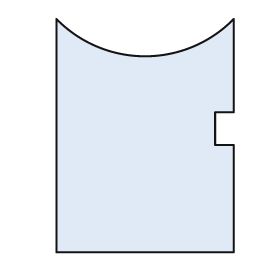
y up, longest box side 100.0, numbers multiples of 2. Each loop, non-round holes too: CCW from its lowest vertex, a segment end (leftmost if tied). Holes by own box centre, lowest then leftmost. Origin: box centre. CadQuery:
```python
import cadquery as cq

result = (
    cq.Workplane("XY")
    .moveTo(-38.0, -50.0)
    .lineTo(38.0, -50.0)
    .lineTo(38.0, -4.0)
    .lineTo(30.0, -4.0)
    .lineTo(30.0, 10.0)
    .lineTo(38.0, 10.0)
    .lineTo(38.0, 50.0)
    .threePointArc((0.0, 34.0), (-38.0, 50.0))
    .close()
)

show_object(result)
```